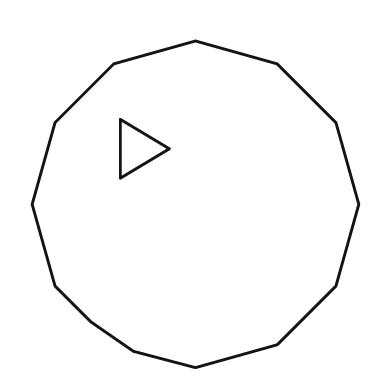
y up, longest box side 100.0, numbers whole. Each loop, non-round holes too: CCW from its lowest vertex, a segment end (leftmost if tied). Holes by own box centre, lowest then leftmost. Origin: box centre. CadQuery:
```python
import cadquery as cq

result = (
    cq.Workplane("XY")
    .moveTo(0.0, -50.0)
    .lineTo(25.0, -43.0)
    .lineTo(43.0, -25.0)
    .lineTo(50.0, 0.0)
    .lineTo(43.0, 25.0)
    .lineTo(25.0, 43.0)
    .lineTo(0.0, 50.0)
    .lineTo(-25.0, 43.0)
    .lineTo(-43.0, 25.0)
    .lineTo(-50.0, 0.0)
    .lineTo(-43.0, -25.0)
    .lineTo(-32.0, -36.0)
    .lineTo(-19.0, -45.0)
    .close()
    .moveTo(-23.0, 8.0)
    .lineTo(-8.0, 17.0)
    .lineTo(-23.0, 26.0)
    .close()
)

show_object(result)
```